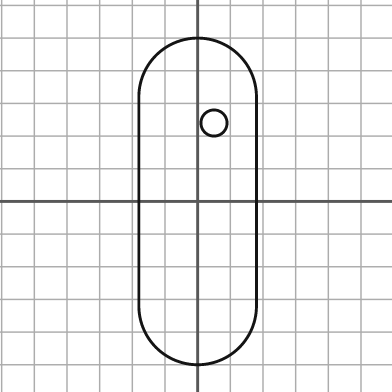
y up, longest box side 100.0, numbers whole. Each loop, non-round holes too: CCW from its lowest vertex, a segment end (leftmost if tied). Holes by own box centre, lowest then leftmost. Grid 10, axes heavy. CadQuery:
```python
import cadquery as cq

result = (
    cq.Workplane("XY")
    .moveTo(-18.0, -32.0)
    .threePointArc((0.0, -50.0), (18.0, -32.0))
    .lineTo(18.0, 32.0)
    .threePointArc((0.0, 50.0), (-18.0, 32.0))
    .close()
    .moveTo(5.0, 24.0)
    .circle(4.0)
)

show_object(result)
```